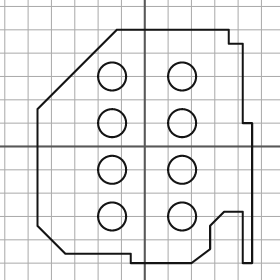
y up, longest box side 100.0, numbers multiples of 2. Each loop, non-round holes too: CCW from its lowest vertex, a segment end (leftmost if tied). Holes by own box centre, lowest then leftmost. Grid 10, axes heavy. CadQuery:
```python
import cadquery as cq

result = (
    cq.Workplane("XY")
    .moveTo(-6.0, -50.0)
    .lineTo(20.0, -50.0)
    .lineTo(28.0, -44.0)
    .lineTo(28.0, -34.0)
    .lineTo(34.0, -28.0)
    .lineTo(42.0, -28.0)
    .lineTo(42.0, -50.0)
    .lineTo(46.0, -50.0)
    .lineTo(46.0, 10.0)
    .lineTo(42.0, 10.0)
    .lineTo(42.0, 44.0)
    .lineTo(36.0, 44.0)
    .lineTo(36.0, 50.0)
    .lineTo(-12.0, 50.0)
    .lineTo(-46.0, 16.0)
    .lineTo(-46.0, -34.0)
    .lineTo(-34.0, -46.0)
    .lineTo(-6.0, -46.0)
    .close()
    .moveTo(-14.0, -30.0)
    .circle(6.0)
    .moveTo(16.0, -30.0)
    .circle(6.0)
    .moveTo(-14.0, -10.0)
    .circle(6.0)
    .moveTo(16.0, -10.0)
    .circle(6.0)
    .moveTo(-14.0, 10.0)
    .circle(6.0)
    .moveTo(16.0, 10.0)
    .circle(6.0)
    .moveTo(-14.0, 30.0)
    .circle(6.0)
    .moveTo(16.0, 30.0)
    .circle(6.0)
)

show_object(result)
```